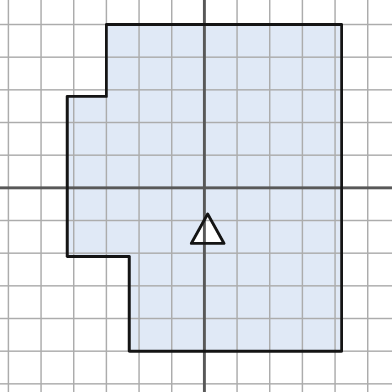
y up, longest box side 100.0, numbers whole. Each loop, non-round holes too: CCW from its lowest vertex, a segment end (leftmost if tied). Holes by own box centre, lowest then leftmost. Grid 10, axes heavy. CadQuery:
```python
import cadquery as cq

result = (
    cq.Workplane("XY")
    .moveTo(-23.0, -50.0)
    .lineTo(42.0, -50.0)
    .lineTo(42.0, 50.0)
    .lineTo(-30.0, 50.0)
    .lineTo(-30.0, 28.0)
    .lineTo(-42.0, 28.0)
    .lineTo(-42.0, -21.0)
    .lineTo(-23.0, -21.0)
    .close()
    .moveTo(-4.0, -17.0)
    .lineTo(6.0, -17.0)
    .lineTo(1.0, -8.0)
    .close()
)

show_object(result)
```